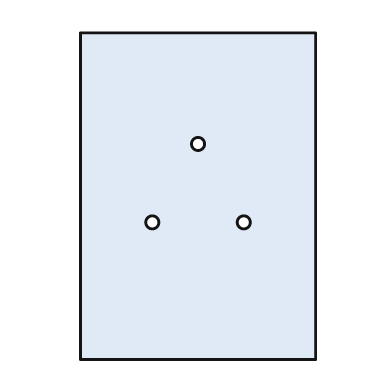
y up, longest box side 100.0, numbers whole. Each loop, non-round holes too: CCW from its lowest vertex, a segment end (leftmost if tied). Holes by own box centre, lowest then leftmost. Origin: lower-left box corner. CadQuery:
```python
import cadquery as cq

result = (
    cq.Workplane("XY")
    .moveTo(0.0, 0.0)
    .lineTo(72.0, 0.0)
    .lineTo(72.0, 100.0)
    .lineTo(0.0, 100.0)
    .close()
    .moveTo(22.0, 42.0)
    .circle(2.0)
    .moveTo(50.0, 42.0)
    .circle(2.0)
    .moveTo(36.0, 66.0)
    .circle(2.0)
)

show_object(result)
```